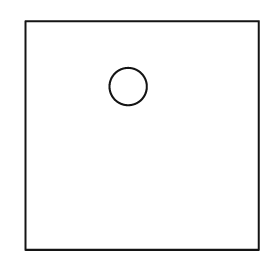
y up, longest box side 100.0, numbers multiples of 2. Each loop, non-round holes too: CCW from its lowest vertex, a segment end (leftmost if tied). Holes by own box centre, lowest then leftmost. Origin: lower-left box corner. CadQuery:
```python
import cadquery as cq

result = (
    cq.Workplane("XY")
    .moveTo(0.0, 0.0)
    .lineTo(100.0, 0.0)
    .lineTo(100.0, 98.0)
    .lineTo(0.0, 98.0)
    .close()
    .moveTo(44.0, 70.0)
    .circle(8.0)
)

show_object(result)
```